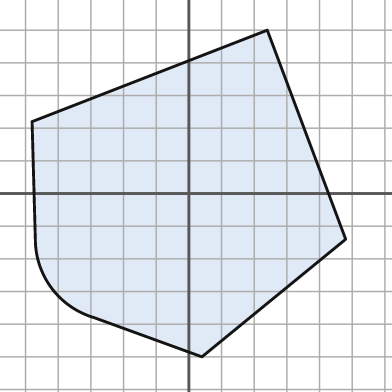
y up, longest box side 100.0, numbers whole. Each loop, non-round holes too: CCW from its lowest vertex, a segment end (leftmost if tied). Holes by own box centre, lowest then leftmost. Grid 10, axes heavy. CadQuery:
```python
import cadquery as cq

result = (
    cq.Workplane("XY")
    .moveTo(4.0, -50.0)
    .lineTo(48.0, -14.0)
    .lineTo(24.0, 50.0)
    .lineTo(-48.0, 22.0)
    .lineTo(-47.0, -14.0)
    .threePointArc((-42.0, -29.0), (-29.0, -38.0))
    .close()
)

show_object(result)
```